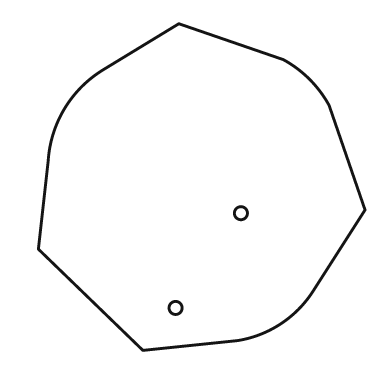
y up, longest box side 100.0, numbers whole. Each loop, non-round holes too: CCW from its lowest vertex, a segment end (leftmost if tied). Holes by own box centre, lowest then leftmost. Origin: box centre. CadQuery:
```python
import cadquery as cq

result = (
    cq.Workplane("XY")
    .moveTo(-18.0, -50.0)
    .lineTo(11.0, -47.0)
    .threePointArc((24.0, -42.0), (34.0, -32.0))
    .lineTo(50.0, -7.0)
    .lineTo(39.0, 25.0)
    .threePointArc((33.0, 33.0), (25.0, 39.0))
    .lineTo(-7.0, 50.0)
    .lineTo(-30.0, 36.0)
    .threePointArc((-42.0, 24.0), (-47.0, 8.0))
    .lineTo(-50.0, -19.0)
    .close()
    .moveTo(-8.0, -37.0)
    .circle(2.0)
    .moveTo(12.0, -8.0)
    .circle(2.0)
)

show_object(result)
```